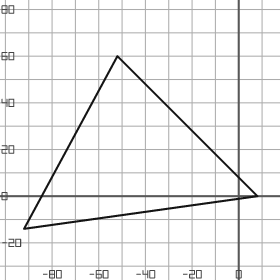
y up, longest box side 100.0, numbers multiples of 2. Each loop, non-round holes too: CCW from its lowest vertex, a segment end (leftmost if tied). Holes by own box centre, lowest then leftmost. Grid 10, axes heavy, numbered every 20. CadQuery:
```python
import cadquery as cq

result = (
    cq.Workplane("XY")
    .moveTo(-92.0, -14.0)
    .lineTo(8.0, 0.0)
    .lineTo(-52.0, 60.0)
    .close()
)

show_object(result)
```